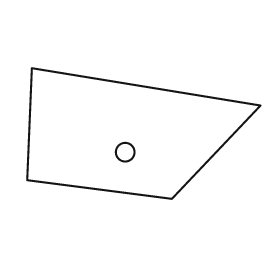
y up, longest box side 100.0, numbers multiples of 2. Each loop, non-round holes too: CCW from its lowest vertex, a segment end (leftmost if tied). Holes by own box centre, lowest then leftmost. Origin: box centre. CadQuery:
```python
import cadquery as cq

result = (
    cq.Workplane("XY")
    .moveTo(12.0, -28.0)
    .lineTo(50.0, 12.0)
    .lineTo(-48.0, 28.0)
    .lineTo(-50.0, -20.0)
    .close()
    .moveTo(-8.0, -8.0)
    .circle(4.0)
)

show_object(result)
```